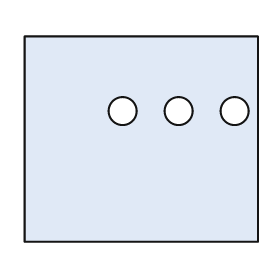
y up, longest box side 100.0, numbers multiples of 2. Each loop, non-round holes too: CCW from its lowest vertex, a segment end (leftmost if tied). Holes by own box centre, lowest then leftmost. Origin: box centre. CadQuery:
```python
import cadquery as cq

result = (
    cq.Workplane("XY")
    .moveTo(-50.0, -44.0)
    .lineTo(50.0, -44.0)
    .lineTo(50.0, 44.0)
    .lineTo(-50.0, 44.0)
    .close()
    .moveTo(-8.0, 12.0)
    .circle(6.0)
    .moveTo(16.0, 12.0)
    .circle(6.0)
    .moveTo(40.0, 12.0)
    .circle(6.0)
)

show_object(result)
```